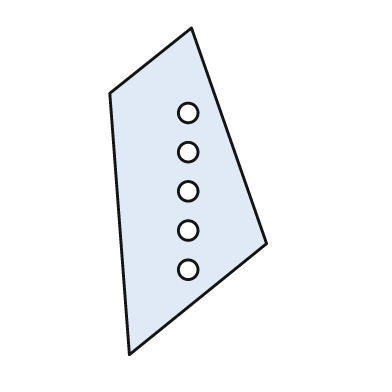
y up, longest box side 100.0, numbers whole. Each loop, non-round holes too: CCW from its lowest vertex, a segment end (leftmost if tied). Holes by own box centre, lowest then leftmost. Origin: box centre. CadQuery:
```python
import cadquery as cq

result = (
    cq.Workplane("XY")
    .moveTo(-18.0, -50.0)
    .lineTo(24.0, -16.0)
    .lineTo(1.0, 50.0)
    .lineTo(-24.0, 30.0)
    .close()
    .moveTo(0.0, -24.0)
    .circle(3.0)
    .moveTo(0.0, -12.0)
    .circle(3.0)
    .moveTo(0.0, 0.0)
    .circle(3.0)
    .moveTo(0.0, 12.0)
    .circle(3.0)
    .moveTo(0.0, 24.0)
    .circle(3.0)
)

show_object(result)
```